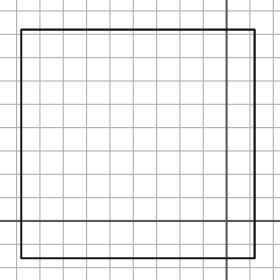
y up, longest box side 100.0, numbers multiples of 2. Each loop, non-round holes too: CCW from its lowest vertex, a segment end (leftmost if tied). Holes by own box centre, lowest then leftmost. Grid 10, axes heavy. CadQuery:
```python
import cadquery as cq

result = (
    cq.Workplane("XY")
    .moveTo(-88.0, -16.0)
    .lineTo(12.0, -16.0)
    .lineTo(12.0, 82.0)
    .lineTo(-88.0, 82.0)
    .close()
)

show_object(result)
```